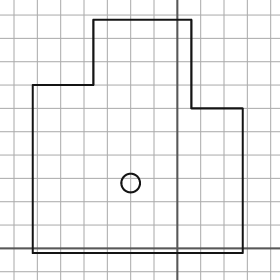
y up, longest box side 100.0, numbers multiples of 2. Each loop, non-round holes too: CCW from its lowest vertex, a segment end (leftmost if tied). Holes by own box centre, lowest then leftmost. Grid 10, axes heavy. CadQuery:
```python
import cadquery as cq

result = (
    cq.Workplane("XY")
    .moveTo(-62.0, -2.0)
    .lineTo(28.0, -2.0)
    .lineTo(28.0, 60.0)
    .lineTo(6.0, 60.0)
    .lineTo(6.0, 98.0)
    .lineTo(-36.0, 98.0)
    .lineTo(-36.0, 70.0)
    .lineTo(-62.0, 70.0)
    .close()
    .moveTo(-20.0, 28.0)
    .circle(4.0)
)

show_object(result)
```